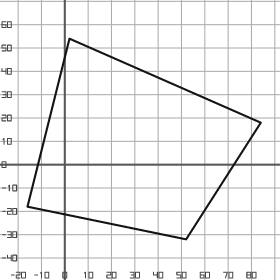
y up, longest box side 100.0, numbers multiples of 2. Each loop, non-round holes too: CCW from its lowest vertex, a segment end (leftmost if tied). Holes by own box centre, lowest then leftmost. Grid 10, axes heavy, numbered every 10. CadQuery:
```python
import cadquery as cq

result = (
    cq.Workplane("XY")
    .moveTo(52.0, -32.0)
    .lineTo(84.0, 18.0)
    .lineTo(2.0, 54.0)
    .lineTo(-16.0, -18.0)
    .close()
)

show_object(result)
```